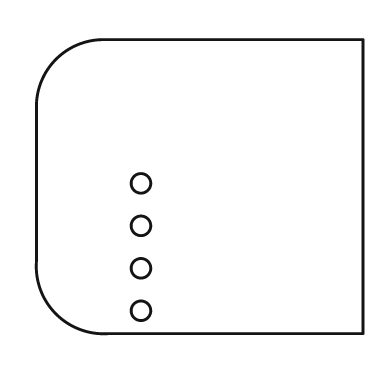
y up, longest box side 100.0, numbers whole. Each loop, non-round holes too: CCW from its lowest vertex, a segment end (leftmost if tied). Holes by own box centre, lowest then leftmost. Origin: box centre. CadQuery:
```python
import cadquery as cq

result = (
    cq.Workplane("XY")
    .moveTo(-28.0, -45.0)
    .lineTo(50.0, -45.0)
    .lineTo(50.0, 45.0)
    .lineTo(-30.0, 45.0)
    .threePointArc((-44.0, 39.0), (-50.0, 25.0))
    .lineTo(-50.0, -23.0)
    .threePointArc((-44.0, -39.0), (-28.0, -45.0))
    .close()
    .moveTo(-18.0, -38.0)
    .circle(3.0)
    .moveTo(-18.0, -25.0)
    .circle(3.0)
    .moveTo(-18.0, -12.0)
    .circle(3.0)
    .moveTo(-18.0, 1.0)
    .circle(3.0)
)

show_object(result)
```